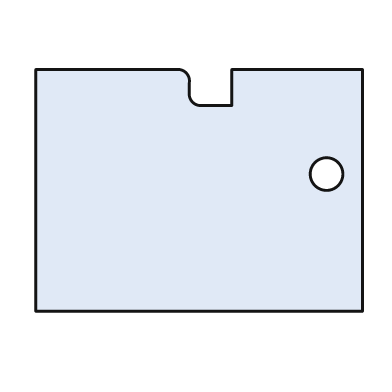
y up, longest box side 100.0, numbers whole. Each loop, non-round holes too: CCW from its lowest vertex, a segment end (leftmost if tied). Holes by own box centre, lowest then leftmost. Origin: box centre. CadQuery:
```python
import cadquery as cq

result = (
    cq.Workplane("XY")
    .moveTo(-50.0, -37.0)
    .lineTo(50.0, -37.0)
    .lineTo(50.0, 37.0)
    .lineTo(10.0, 37.0)
    .lineTo(10.0, 26.0)
    .lineTo(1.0, 26.0)
    .threePointArc((-2.0, 27.0), (-3.0, 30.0))
    .lineTo(-3.0, 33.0)
    .threePointArc((-4.0, 36.0), (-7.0, 37.0))
    .lineTo(-50.0, 37.0)
    .close()
    .moveTo(39.0, 5.0)
    .circle(5.0)
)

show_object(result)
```